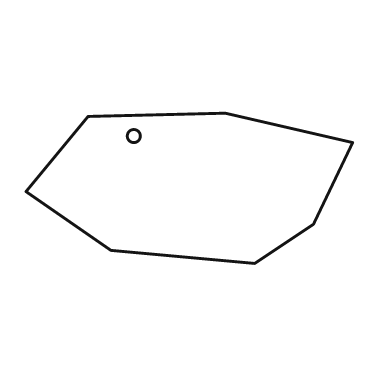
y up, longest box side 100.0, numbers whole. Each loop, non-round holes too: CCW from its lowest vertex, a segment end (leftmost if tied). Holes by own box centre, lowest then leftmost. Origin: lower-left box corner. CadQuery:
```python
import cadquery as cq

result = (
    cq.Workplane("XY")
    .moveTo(70.0, 0.0)
    .lineTo(88.0, 12.0)
    .lineTo(100.0, 37.0)
    .lineTo(61.0, 46.0)
    .lineTo(19.0, 45.0)
    .lineTo(0.0, 22.0)
    .lineTo(26.0, 4.0)
    .close()
    .moveTo(33.0, 39.0)
    .circle(2.0)
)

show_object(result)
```